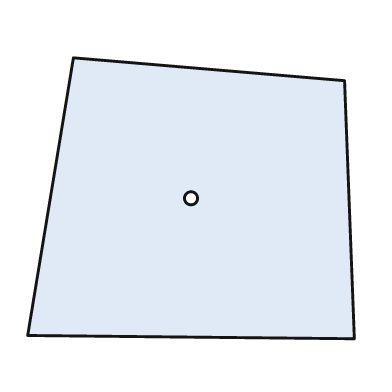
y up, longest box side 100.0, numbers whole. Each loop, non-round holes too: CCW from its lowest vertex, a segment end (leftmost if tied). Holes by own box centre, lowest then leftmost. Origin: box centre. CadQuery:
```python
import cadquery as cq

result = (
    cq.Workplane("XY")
    .moveTo(50.0, -43.0)
    .lineTo(47.0, 36.0)
    .lineTo(-36.0, 43.0)
    .lineTo(-50.0, -42.0)
    .close()
    .moveTo(0.0, 0.0)
    .circle(2.0)
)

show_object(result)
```